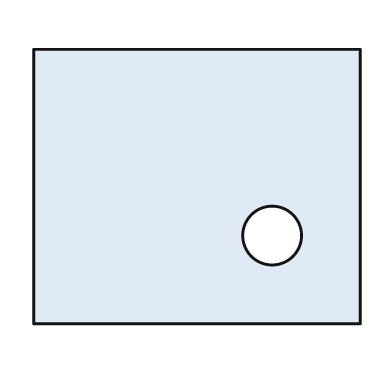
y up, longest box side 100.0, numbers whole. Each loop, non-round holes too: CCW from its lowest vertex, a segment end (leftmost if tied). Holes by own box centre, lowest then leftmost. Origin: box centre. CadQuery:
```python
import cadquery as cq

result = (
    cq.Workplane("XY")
    .moveTo(-50.0, -42.0)
    .lineTo(50.0, -42.0)
    .lineTo(50.0, 42.0)
    .lineTo(-50.0, 42.0)
    .close()
    .moveTo(23.0, -15.0)
    .circle(9.0)
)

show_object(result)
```